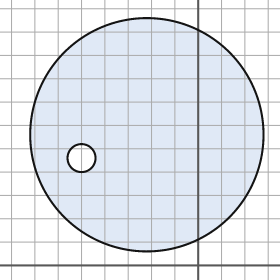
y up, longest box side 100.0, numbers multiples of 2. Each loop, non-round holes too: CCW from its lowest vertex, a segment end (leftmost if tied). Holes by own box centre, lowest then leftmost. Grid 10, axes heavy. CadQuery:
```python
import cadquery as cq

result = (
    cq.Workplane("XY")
    .moveTo(-22.0, 56.0)
    .circle(50.0)
    .moveTo(-50.0, 46.0)
    .circle(6.0)
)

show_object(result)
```